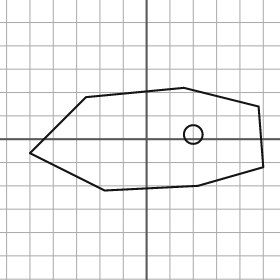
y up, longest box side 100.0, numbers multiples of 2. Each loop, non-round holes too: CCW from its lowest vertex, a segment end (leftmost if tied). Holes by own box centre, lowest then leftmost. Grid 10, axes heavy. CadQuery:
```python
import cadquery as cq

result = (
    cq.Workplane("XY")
    .moveTo(-18.0, -22.0)
    .lineTo(22.0, -20.0)
    .lineTo(50.0, -12.0)
    .lineTo(48.0, 14.0)
    .lineTo(16.0, 22.0)
    .lineTo(-26.0, 18.0)
    .lineTo(-50.0, -6.0)
    .close()
    .moveTo(20.0, 2.0)
    .circle(4.0)
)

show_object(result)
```